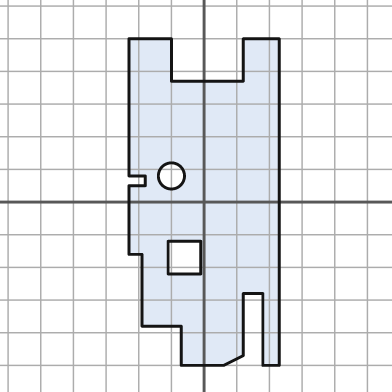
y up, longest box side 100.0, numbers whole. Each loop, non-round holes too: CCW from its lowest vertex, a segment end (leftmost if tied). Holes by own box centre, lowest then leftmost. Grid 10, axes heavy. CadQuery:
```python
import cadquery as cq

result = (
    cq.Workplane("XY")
    .moveTo(-7.0, -50.0)
    .lineTo(6.0, -50.0)
    .lineTo(12.0, -47.0)
    .lineTo(12.0, -28.0)
    .lineTo(18.0, -28.0)
    .lineTo(18.0, -50.0)
    .lineTo(23.0, -50.0)
    .lineTo(23.0, 50.0)
    .lineTo(12.0, 50.0)
    .lineTo(12.0, 37.0)
    .lineTo(-10.0, 37.0)
    .lineTo(-10.0, 50.0)
    .lineTo(-23.0, 50.0)
    .lineTo(-23.0, 8.0)
    .lineTo(-18.0, 8.0)
    .lineTo(-18.0, 5.0)
    .lineTo(-23.0, 5.0)
    .lineTo(-23.0, -16.0)
    .lineTo(-19.0, -16.0)
    .lineTo(-19.0, -38.0)
    .lineTo(-7.0, -38.0)
    .close()
    .moveTo(-11.0, -22.0)
    .lineTo(-1.0, -22.0)
    .lineTo(-1.0, -12.0)
    .lineTo(-11.0, -12.0)
    .close()
    .moveTo(-10.0, 8.0)
    .circle(4.0)
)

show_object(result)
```